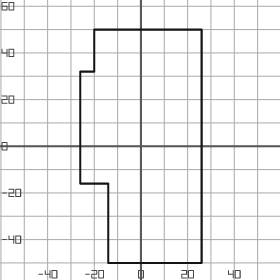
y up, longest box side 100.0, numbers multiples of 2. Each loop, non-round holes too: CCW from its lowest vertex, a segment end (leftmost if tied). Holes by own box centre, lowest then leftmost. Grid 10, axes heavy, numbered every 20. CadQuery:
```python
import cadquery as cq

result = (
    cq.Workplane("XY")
    .moveTo(-14.0, -50.0)
    .lineTo(26.0, -50.0)
    .lineTo(26.0, 50.0)
    .lineTo(-20.0, 50.0)
    .lineTo(-20.0, 32.0)
    .lineTo(-26.0, 32.0)
    .lineTo(-26.0, -16.0)
    .lineTo(-14.0, -16.0)
    .close()
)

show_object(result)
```